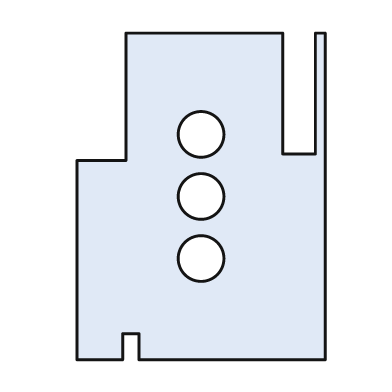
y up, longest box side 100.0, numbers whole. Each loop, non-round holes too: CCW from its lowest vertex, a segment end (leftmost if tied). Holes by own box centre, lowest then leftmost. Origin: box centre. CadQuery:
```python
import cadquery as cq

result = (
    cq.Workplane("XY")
    .moveTo(-38.0, -50.0)
    .lineTo(-24.0, -50.0)
    .lineTo(-24.0, -42.0)
    .lineTo(-19.0, -42.0)
    .lineTo(-19.0, -50.0)
    .lineTo(38.0, -50.0)
    .lineTo(38.0, 50.0)
    .lineTo(35.0, 50.0)
    .lineTo(35.0, 13.0)
    .lineTo(25.0, 13.0)
    .lineTo(25.0, 50.0)
    .lineTo(-23.0, 50.0)
    .lineTo(-23.0, 11.0)
    .lineTo(-38.0, 11.0)
    .close()
    .moveTo(0.0, -19.0)
    .circle(7.0)
    .moveTo(0.0, 0.0)
    .circle(7.0)
    .moveTo(0.0, 19.0)
    .circle(7.0)
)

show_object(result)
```